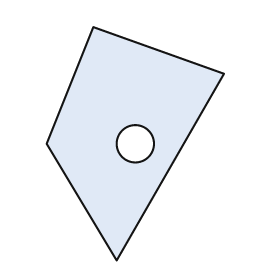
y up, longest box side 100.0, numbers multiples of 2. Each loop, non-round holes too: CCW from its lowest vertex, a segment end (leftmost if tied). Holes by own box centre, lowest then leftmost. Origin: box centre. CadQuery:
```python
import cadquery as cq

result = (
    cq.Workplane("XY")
    .moveTo(-8.0, -50.0)
    .lineTo(38.0, 30.0)
    .lineTo(-18.0, 50.0)
    .lineTo(-38.0, 0.0)
    .close()
    .moveTo(0.0, 0.0)
    .circle(8.0)
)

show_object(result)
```